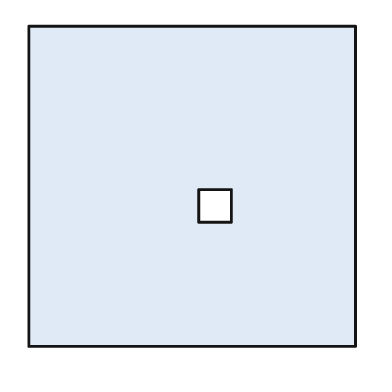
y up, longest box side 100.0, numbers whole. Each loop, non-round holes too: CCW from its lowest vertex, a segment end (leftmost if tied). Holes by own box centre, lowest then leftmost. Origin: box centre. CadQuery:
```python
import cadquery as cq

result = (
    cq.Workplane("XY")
    .moveTo(-50.0, -49.0)
    .lineTo(50.0, -49.0)
    .lineTo(50.0, 49.0)
    .lineTo(-50.0, 49.0)
    .close()
    .moveTo(2.0, -11.0)
    .lineTo(12.0, -11.0)
    .lineTo(12.0, -1.0)
    .lineTo(2.0, -1.0)
    .close()
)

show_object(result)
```